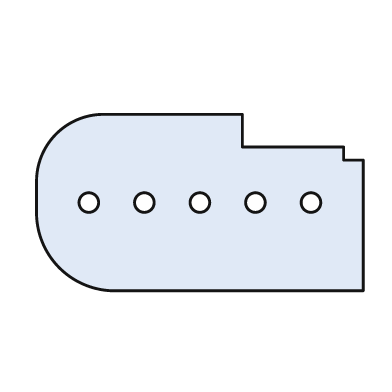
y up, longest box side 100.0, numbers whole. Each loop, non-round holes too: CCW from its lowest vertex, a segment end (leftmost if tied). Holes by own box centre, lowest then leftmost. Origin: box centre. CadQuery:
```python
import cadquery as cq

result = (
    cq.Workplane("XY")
    .moveTo(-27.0, -27.0)
    .lineTo(50.0, -27.0)
    .lineTo(50.0, 13.0)
    .lineTo(44.0, 13.0)
    .lineTo(44.0, 17.0)
    .lineTo(13.0, 17.0)
    .lineTo(13.0, 27.0)
    .lineTo(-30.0, 27.0)
    .threePointArc((-44.0, 21.0), (-50.0, 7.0))
    .lineTo(-50.0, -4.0)
    .threePointArc((-43.0, -20.0), (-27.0, -27.0))
    .close()
    .moveTo(-34.0, 0.0)
    .circle(3.0)
    .moveTo(-17.0, 0.0)
    .circle(3.0)
    .moveTo(0.0, 0.0)
    .circle(3.0)
    .moveTo(17.0, 0.0)
    .circle(3.0)
    .moveTo(34.0, 0.0)
    .circle(3.0)
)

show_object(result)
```